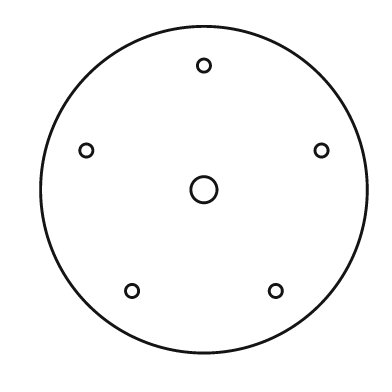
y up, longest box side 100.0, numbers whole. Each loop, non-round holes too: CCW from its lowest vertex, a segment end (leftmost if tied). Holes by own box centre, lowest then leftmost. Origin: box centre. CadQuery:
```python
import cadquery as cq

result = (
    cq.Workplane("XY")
    .moveTo(0.0, 0.0)
    .circle(50.0)
    .moveTo(-22.0, -31.0)
    .circle(2.0)
    .moveTo(22.0, -31.0)
    .circle(2.0)
    .moveTo(0.0, 0.0)
    .circle(4.0)
    .moveTo(-36.0, 12.0)
    .circle(2.0)
    .moveTo(36.0, 12.0)
    .circle(2.0)
    .moveTo(0.0, 38.0)
    .circle(2.0)
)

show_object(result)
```